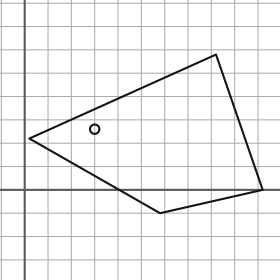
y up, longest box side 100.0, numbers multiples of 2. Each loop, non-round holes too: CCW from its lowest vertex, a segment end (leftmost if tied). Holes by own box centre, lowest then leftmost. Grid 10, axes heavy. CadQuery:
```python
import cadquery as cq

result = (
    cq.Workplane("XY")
    .moveTo(58.0, -10.0)
    .lineTo(102.0, 0.0)
    .lineTo(82.0, 58.0)
    .lineTo(2.0, 22.0)
    .close()
    .moveTo(30.0, 26.0)
    .circle(2.0)
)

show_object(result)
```